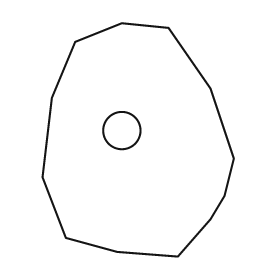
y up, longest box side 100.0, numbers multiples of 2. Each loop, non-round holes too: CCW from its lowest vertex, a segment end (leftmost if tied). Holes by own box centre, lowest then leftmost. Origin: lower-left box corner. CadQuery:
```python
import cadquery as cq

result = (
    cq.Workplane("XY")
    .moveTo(58.0, 0.0)
    .lineTo(72.0, 16.0)
    .lineTo(78.0, 26.0)
    .lineTo(82.0, 42.0)
    .lineTo(72.0, 72.0)
    .lineTo(54.0, 98.0)
    .lineTo(34.0, 100.0)
    .lineTo(14.0, 92.0)
    .lineTo(4.0, 68.0)
    .lineTo(0.0, 34.0)
    .lineTo(10.0, 8.0)
    .lineTo(32.0, 2.0)
    .close()
    .moveTo(34.0, 54.0)
    .circle(8.0)
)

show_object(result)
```